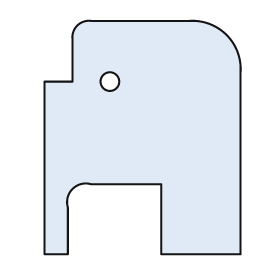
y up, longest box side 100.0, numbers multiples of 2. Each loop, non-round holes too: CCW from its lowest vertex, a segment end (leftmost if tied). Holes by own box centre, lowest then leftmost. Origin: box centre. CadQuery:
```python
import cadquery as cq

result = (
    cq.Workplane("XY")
    .moveTo(-42.0, -50.0)
    .lineTo(-32.0, -50.0)
    .lineTo(-32.0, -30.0)
    .threePointArc((-30.0, -22.0), (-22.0, -20.0))
    .lineTo(8.0, -20.0)
    .lineTo(8.0, -50.0)
    .lineTo(42.0, -50.0)
    .lineTo(42.0, 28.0)
    .threePointArc((36.0, 44.0), (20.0, 50.0))
    .lineTo(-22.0, 50.0)
    .threePointArc((-28.0, 48.0), (-30.0, 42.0))
    .lineTo(-30.0, 24.0)
    .lineTo(-42.0, 24.0)
    .close()
    .moveTo(-14.0, 24.0)
    .circle(4.0)
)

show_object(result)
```